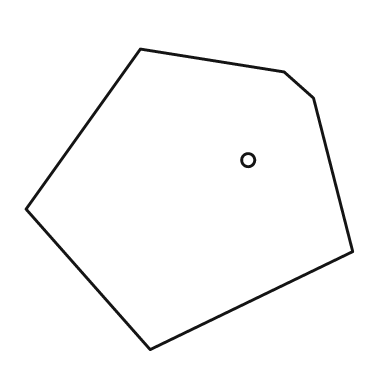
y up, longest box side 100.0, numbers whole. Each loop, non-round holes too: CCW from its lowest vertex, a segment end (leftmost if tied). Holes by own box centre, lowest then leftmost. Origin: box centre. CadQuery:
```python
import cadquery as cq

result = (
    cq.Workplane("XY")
    .moveTo(-12.0, -46.0)
    .lineTo(50.0, -16.0)
    .lineTo(38.0, 31.0)
    .lineTo(29.0, 39.0)
    .lineTo(-15.0, 46.0)
    .lineTo(-50.0, -3.0)
    .close()
    .moveTo(18.0, 12.0)
    .circle(2.0)
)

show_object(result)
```